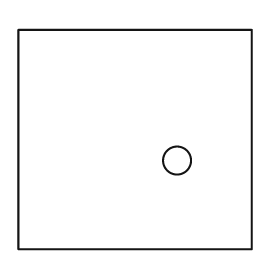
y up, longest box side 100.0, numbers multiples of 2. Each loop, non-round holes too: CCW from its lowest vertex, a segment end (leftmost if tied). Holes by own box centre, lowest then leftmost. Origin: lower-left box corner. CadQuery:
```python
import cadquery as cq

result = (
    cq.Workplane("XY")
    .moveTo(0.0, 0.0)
    .lineTo(100.0, 0.0)
    .lineTo(100.0, 94.0)
    .lineTo(0.0, 94.0)
    .close()
    .moveTo(68.0, 38.0)
    .circle(6.0)
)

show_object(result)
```